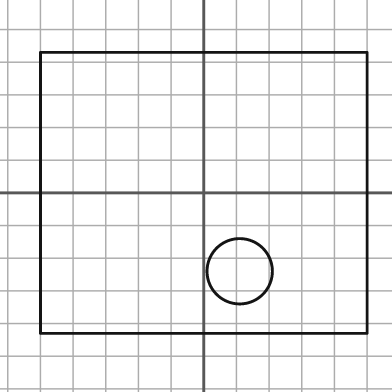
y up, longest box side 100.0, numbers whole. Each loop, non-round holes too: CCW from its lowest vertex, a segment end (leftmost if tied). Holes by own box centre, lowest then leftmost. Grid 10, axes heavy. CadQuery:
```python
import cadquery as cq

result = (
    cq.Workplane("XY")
    .moveTo(-50.0, -43.0)
    .lineTo(50.0, -43.0)
    .lineTo(50.0, 43.0)
    .lineTo(-50.0, 43.0)
    .close()
    .moveTo(11.0, -24.0)
    .circle(10.0)
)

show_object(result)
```